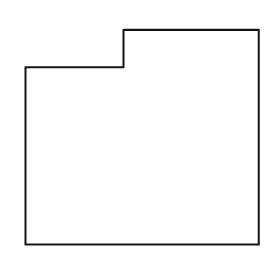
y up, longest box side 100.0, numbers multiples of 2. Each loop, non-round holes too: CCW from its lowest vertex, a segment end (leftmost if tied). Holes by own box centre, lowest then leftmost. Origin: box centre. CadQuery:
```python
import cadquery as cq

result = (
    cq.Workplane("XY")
    .moveTo(-50.0, -46.0)
    .lineTo(50.0, -46.0)
    .lineTo(50.0, 46.0)
    .lineTo(-8.0, 46.0)
    .lineTo(-8.0, 30.0)
    .lineTo(-50.0, 30.0)
    .close()
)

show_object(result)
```